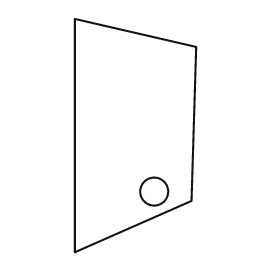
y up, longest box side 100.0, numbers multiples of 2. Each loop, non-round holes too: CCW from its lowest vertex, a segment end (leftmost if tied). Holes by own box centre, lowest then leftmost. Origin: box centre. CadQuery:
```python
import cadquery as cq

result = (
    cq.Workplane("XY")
    .moveTo(-26.0, -50.0)
    .lineTo(24.0, -28.0)
    .lineTo(26.0, 38.0)
    .lineTo(-26.0, 50.0)
    .close()
    .moveTo(8.0, -24.0)
    .circle(6.0)
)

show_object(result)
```